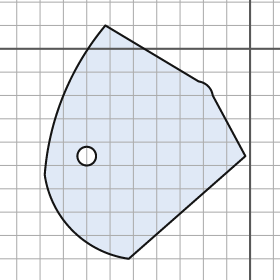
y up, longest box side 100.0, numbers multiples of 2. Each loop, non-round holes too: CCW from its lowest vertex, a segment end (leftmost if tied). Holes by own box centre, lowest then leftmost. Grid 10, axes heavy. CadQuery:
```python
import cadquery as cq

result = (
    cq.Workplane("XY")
    .moveTo(-52.0, -90.0)
    .lineTo(-2.0, -46.0)
    .lineTo(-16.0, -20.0)
    .threePointArc((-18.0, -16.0), (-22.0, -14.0))
    .lineTo(-62.0, 10.0)
    .threePointArc((-80.0, -20.0), (-88.0, -54.0))
    .threePointArc((-76.0, -78.0), (-52.0, -90.0))
    .close()
    .moveTo(-70.0, -46.0)
    .circle(4.0)
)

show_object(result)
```